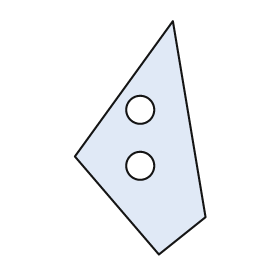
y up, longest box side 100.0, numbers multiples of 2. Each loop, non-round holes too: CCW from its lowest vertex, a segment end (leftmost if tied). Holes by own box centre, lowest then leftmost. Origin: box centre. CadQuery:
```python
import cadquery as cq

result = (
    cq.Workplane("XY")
    .moveTo(8.0, -50.0)
    .lineTo(28.0, -34.0)
    .lineTo(14.0, 50.0)
    .lineTo(-28.0, -8.0)
    .close()
    .moveTo(0.0, -12.0)
    .circle(6.0)
    .moveTo(0.0, 12.0)
    .circle(6.0)
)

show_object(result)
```